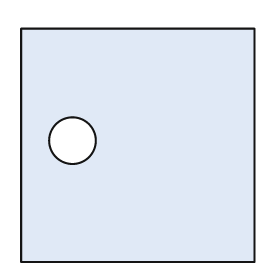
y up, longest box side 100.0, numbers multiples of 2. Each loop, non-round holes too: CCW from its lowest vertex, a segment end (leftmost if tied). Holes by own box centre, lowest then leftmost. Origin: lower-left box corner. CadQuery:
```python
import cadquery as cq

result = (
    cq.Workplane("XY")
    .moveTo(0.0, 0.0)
    .lineTo(100.0, 0.0)
    .lineTo(100.0, 100.0)
    .lineTo(0.0, 100.0)
    .close()
    .moveTo(22.0, 52.0)
    .circle(10.0)
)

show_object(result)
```